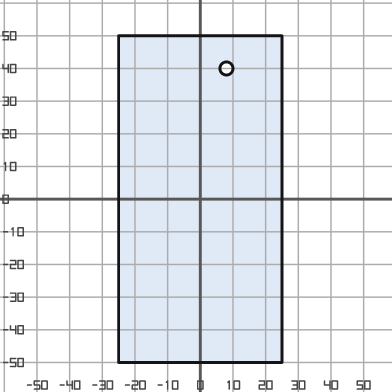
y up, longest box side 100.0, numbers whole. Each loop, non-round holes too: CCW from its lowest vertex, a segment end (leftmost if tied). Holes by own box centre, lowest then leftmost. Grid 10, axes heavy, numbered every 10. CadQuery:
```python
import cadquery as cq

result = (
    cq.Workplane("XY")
    .moveTo(-25.0, -50.0)
    .lineTo(25.0, -50.0)
    .lineTo(25.0, 50.0)
    .lineTo(-25.0, 50.0)
    .close()
    .moveTo(8.0, 40.0)
    .circle(2.0)
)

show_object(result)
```